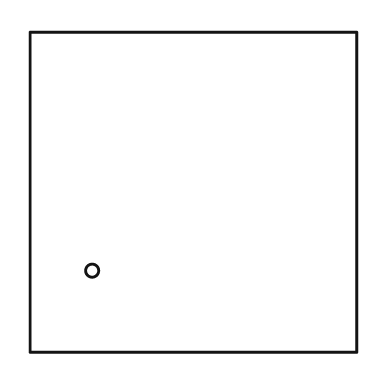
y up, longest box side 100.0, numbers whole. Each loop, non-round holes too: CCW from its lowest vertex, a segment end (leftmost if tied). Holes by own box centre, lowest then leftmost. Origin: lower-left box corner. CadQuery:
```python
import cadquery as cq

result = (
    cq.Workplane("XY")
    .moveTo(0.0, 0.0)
    .lineTo(100.0, 0.0)
    .lineTo(100.0, 98.0)
    .lineTo(0.0, 98.0)
    .close()
    .moveTo(19.0, 25.0)
    .circle(2.0)
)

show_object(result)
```